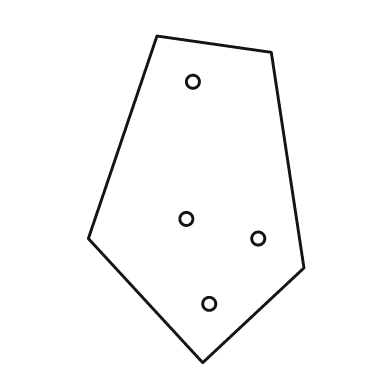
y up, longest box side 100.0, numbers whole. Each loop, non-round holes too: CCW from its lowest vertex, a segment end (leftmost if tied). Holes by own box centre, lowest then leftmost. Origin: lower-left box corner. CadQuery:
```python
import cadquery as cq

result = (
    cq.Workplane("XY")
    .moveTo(35.0, 0.0)
    .lineTo(66.0, 29.0)
    .lineTo(56.0, 95.0)
    .lineTo(21.0, 100.0)
    .lineTo(0.0, 38.0)
    .close()
    .moveTo(37.0, 18.0)
    .circle(2.0)
    .moveTo(52.0, 38.0)
    .circle(2.0)
    .moveTo(30.0, 44.0)
    .circle(2.0)
    .moveTo(32.0, 86.0)
    .circle(2.0)
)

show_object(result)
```